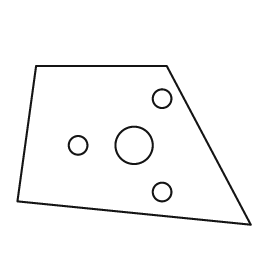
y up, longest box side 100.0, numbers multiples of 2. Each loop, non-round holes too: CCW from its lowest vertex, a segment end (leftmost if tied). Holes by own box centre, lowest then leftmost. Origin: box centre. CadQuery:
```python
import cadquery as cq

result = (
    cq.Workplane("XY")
    .moveTo(50.0, -34.0)
    .lineTo(14.0, 34.0)
    .lineTo(-42.0, 34.0)
    .lineTo(-50.0, -24.0)
    .close()
    .moveTo(12.0, -20.0)
    .circle(4.0)
    .moveTo(-24.0, 0.0)
    .circle(4.0)
    .moveTo(0.0, 0.0)
    .circle(8.0)
    .moveTo(12.0, 20.0)
    .circle(4.0)
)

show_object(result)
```